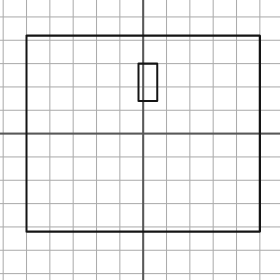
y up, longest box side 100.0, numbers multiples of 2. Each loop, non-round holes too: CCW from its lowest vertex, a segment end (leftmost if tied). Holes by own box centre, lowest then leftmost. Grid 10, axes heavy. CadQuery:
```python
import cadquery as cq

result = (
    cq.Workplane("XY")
    .moveTo(-50.0, -42.0)
    .lineTo(50.0, -42.0)
    .lineTo(50.0, 42.0)
    .lineTo(-50.0, 42.0)
    .close()
    .moveTo(-2.0, 14.0)
    .lineTo(6.0, 14.0)
    .lineTo(6.0, 30.0)
    .lineTo(-2.0, 30.0)
    .close()
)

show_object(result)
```